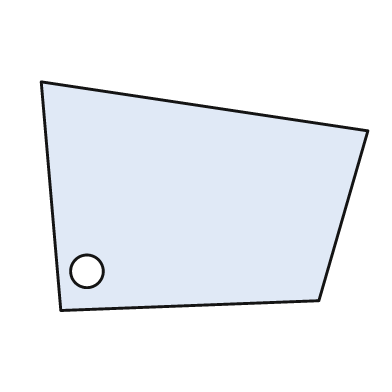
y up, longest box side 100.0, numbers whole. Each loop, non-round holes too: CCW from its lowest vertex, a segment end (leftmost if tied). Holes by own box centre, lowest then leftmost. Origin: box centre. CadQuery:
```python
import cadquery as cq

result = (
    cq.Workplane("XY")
    .moveTo(-44.0, -35.0)
    .lineTo(35.0, -32.0)
    .lineTo(50.0, 20.0)
    .lineTo(-50.0, 35.0)
    .close()
    .moveTo(-36.0, -23.0)
    .circle(5.0)
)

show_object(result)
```